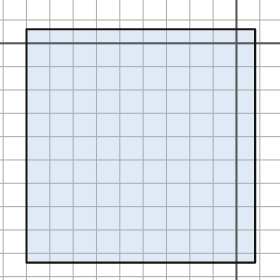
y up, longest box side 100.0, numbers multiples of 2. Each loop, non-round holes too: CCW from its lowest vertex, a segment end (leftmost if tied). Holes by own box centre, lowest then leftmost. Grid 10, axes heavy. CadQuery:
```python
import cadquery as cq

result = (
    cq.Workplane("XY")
    .moveTo(-90.0, -94.0)
    .lineTo(8.0, -94.0)
    .lineTo(8.0, 6.0)
    .lineTo(-90.0, 6.0)
    .close()
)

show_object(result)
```